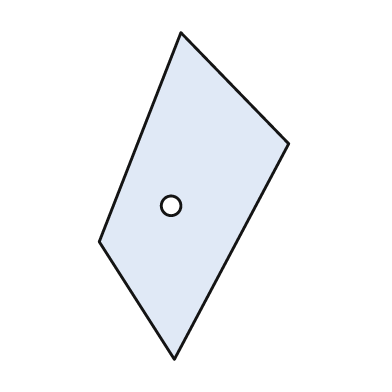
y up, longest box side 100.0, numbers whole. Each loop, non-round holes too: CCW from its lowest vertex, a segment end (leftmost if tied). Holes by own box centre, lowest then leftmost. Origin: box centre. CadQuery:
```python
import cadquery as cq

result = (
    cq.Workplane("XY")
    .moveTo(-6.0, -50.0)
    .lineTo(29.0, 16.0)
    .lineTo(-4.0, 50.0)
    .lineTo(-29.0, -14.0)
    .close()
    .moveTo(-7.0, -3.0)
    .circle(3.0)
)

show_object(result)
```